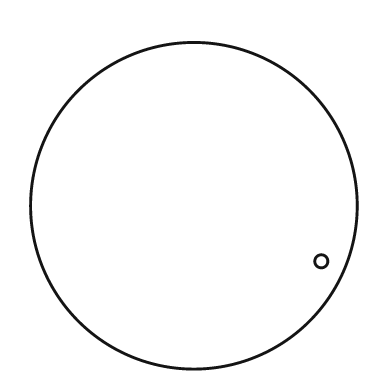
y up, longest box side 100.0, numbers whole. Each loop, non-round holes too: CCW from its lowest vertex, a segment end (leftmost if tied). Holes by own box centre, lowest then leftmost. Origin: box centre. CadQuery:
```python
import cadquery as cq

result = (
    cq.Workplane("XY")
    .moveTo(0.0, 0.0)
    .circle(50.0)
    .moveTo(39.0, -17.0)
    .circle(2.0)
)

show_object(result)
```